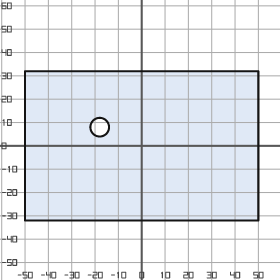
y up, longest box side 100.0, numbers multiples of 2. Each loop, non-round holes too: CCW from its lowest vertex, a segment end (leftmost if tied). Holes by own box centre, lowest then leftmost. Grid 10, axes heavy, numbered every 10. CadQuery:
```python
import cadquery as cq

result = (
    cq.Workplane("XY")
    .moveTo(-50.0, -32.0)
    .lineTo(50.0, -32.0)
    .lineTo(50.0, 32.0)
    .lineTo(-50.0, 32.0)
    .close()
    .moveTo(-18.0, 8.0)
    .circle(4.0)
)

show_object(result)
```